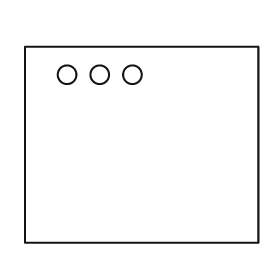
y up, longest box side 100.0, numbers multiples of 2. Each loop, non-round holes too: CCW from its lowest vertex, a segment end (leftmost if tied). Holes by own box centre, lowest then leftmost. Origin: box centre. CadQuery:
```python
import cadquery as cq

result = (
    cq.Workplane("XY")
    .moveTo(-50.0, -42.0)
    .lineTo(50.0, -42.0)
    .lineTo(50.0, 42.0)
    .lineTo(-50.0, 42.0)
    .close()
    .moveTo(-32.0, 30.0)
    .circle(4.0)
    .moveTo(-18.0, 30.0)
    .circle(4.0)
    .moveTo(-4.0, 30.0)
    .circle(4.0)
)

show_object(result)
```